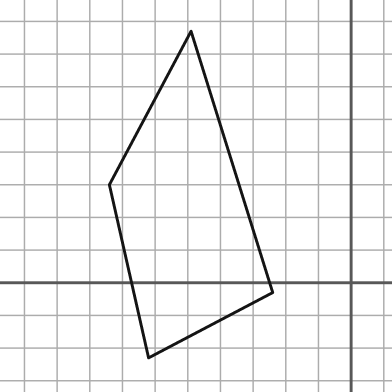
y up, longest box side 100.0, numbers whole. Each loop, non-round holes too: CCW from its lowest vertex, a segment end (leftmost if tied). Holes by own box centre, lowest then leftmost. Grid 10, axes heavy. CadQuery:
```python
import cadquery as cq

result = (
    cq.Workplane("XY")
    .moveTo(-62.0, -23.0)
    .lineTo(-24.0, -3.0)
    .lineTo(-49.0, 77.0)
    .lineTo(-74.0, 30.0)
    .close()
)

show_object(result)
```